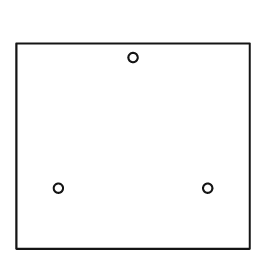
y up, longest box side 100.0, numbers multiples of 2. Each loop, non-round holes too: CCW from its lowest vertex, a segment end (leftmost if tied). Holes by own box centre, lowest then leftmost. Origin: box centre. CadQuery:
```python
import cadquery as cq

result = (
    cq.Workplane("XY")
    .moveTo(-50.0, -44.0)
    .lineTo(50.0, -44.0)
    .lineTo(50.0, 44.0)
    .lineTo(-50.0, 44.0)
    .close()
    .moveTo(-32.0, -18.0)
    .circle(2.0)
    .moveTo(32.0, -18.0)
    .circle(2.0)
    .moveTo(0.0, 38.0)
    .circle(2.0)
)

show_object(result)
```